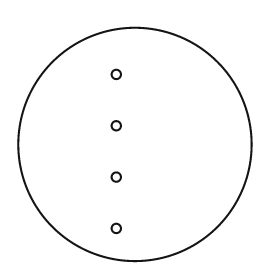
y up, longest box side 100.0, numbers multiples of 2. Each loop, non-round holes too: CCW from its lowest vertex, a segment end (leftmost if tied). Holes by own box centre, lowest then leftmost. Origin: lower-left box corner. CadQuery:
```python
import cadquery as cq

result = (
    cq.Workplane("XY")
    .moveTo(50.0, 50.0)
    .circle(50.0)
    .moveTo(42.0, 14.0)
    .circle(2.0)
    .moveTo(42.0, 36.0)
    .circle(2.0)
    .moveTo(42.0, 58.0)
    .circle(2.0)
    .moveTo(42.0, 80.0)
    .circle(2.0)
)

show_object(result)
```